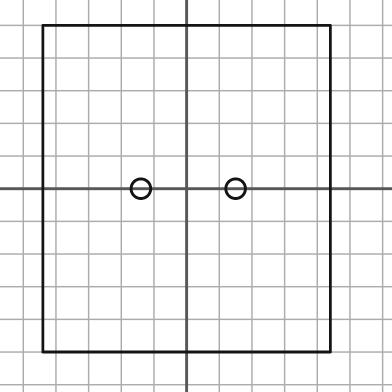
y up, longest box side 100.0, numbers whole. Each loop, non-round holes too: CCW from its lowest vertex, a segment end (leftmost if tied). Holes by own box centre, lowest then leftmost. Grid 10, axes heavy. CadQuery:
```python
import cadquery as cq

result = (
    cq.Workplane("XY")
    .moveTo(-44.0, -50.0)
    .lineTo(44.0, -50.0)
    .lineTo(44.0, 50.0)
    .lineTo(-44.0, 50.0)
    .close()
    .moveTo(-14.0, 0.0)
    .circle(3.0)
    .moveTo(15.0, 0.0)
    .circle(3.0)
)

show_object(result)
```